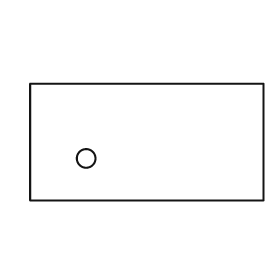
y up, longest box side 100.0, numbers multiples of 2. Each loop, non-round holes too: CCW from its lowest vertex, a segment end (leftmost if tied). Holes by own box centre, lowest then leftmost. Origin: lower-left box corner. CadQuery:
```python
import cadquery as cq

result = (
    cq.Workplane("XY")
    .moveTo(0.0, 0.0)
    .lineTo(100.0, 0.0)
    .lineTo(100.0, 50.0)
    .lineTo(0.0, 50.0)
    .close()
    .moveTo(24.0, 18.0)
    .circle(4.0)
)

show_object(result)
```